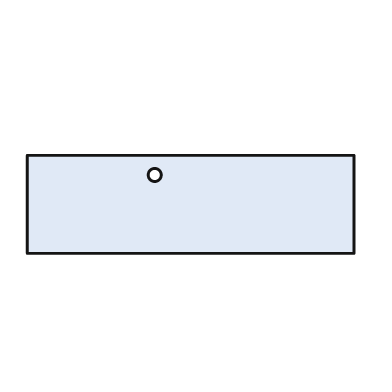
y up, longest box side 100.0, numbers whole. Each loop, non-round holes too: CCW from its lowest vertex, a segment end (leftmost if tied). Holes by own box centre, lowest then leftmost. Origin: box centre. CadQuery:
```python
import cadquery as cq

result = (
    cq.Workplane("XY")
    .moveTo(-50.0, -15.0)
    .lineTo(50.0, -15.0)
    .lineTo(50.0, 15.0)
    .lineTo(-50.0, 15.0)
    .close()
    .moveTo(-11.0, 9.0)
    .circle(2.0)
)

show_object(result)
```